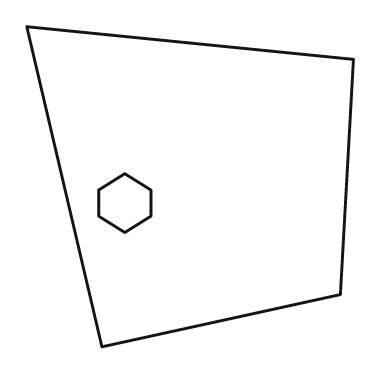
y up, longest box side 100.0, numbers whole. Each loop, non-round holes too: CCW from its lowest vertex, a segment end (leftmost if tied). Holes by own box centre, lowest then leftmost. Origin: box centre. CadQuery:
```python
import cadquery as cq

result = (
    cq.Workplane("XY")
    .moveTo(-27.0, -49.0)
    .lineTo(46.0, -33.0)
    .lineTo(50.0, 39.0)
    .lineTo(-50.0, 49.0)
    .close()
    .moveTo(-20.0, -14.0)
    .lineTo(-12.0, -9.0)
    .lineTo(-12.0, -1.0)
    .lineTo(-20.0, 4.0)
    .lineTo(-28.0, -1.0)
    .lineTo(-28.0, -9.0)
    .close()
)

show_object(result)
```